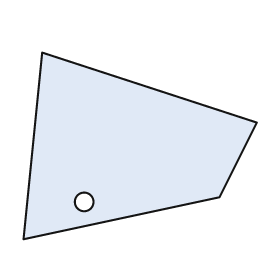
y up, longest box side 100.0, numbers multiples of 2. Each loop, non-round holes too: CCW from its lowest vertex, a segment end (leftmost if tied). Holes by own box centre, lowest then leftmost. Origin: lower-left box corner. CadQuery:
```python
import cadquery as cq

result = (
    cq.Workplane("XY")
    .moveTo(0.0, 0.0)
    .lineTo(84.0, 18.0)
    .lineTo(100.0, 50.0)
    .lineTo(8.0, 80.0)
    .close()
    .moveTo(26.0, 16.0)
    .circle(4.0)
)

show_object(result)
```